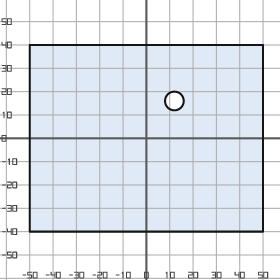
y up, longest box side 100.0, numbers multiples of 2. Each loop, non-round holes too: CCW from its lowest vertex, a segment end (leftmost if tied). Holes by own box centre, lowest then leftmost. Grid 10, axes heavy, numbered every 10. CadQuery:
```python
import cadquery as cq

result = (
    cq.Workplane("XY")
    .moveTo(-50.0, -40.0)
    .lineTo(50.0, -40.0)
    .lineTo(50.0, 40.0)
    .lineTo(-50.0, 40.0)
    .close()
    .moveTo(12.0, 16.0)
    .circle(4.0)
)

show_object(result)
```